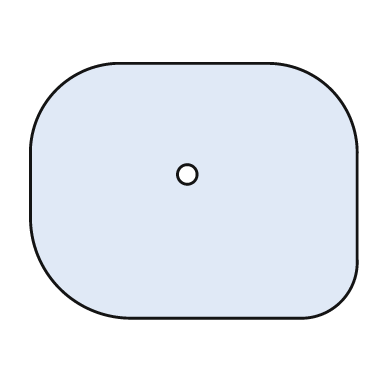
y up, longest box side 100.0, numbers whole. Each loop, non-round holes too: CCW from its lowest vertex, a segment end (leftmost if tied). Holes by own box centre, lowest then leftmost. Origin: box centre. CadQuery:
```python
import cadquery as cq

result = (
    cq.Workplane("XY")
    .moveTo(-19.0, -39.0)
    .lineTo(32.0, -39.0)
    .threePointArc((45.0, -34.0), (50.0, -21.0))
    .lineTo(50.0, 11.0)
    .threePointArc((42.0, 31.0), (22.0, 39.0))
    .lineTo(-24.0, 39.0)
    .threePointArc((-42.0, 31.0), (-50.0, 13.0))
    .lineTo(-50.0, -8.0)
    .threePointArc((-41.0, -30.0), (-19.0, -39.0))
    .close()
    .moveTo(-2.0, 5.0)
    .circle(3.0)
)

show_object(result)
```